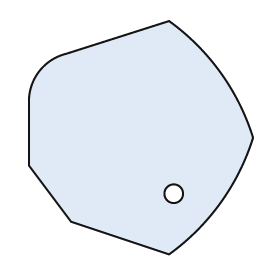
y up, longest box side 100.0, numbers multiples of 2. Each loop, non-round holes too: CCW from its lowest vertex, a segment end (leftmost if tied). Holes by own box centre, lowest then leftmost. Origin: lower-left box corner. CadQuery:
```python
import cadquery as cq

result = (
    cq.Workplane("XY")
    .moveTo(60.0, 0.0)
    .threePointArc((82.0, 22.0), (96.0, 50.0))
    .threePointArc((82.0, 78.0), (60.0, 100.0))
    .lineTo(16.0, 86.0)
    .threePointArc((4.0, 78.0), (0.0, 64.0))
    .lineTo(0.0, 38.0)
    .lineTo(18.0, 14.0)
    .close()
    .moveTo(62.0, 26.0)
    .circle(4.0)
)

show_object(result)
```